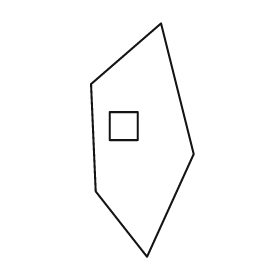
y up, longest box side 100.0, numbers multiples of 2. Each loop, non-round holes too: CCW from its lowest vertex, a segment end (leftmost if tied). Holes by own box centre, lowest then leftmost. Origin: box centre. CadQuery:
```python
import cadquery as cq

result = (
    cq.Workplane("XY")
    .moveTo(2.0, -50.0)
    .lineTo(22.0, -6.0)
    .lineTo(8.0, 50.0)
    .lineTo(-22.0, 24.0)
    .lineTo(-20.0, -22.0)
    .close()
    .moveTo(-14.0, 0.0)
    .lineTo(-2.0, 0.0)
    .lineTo(-2.0, 12.0)
    .lineTo(-14.0, 12.0)
    .close()
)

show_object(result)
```